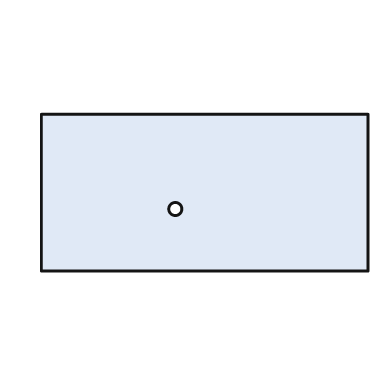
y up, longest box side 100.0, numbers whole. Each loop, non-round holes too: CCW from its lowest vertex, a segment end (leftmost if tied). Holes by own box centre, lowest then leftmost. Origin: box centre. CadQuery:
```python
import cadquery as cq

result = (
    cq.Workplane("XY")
    .moveTo(-50.0, -24.0)
    .lineTo(50.0, -24.0)
    .lineTo(50.0, 24.0)
    .lineTo(-50.0, 24.0)
    .close()
    .moveTo(-9.0, -5.0)
    .circle(2.0)
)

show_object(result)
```